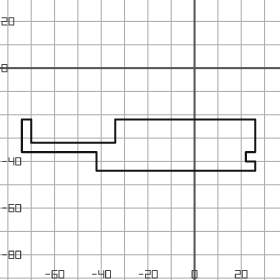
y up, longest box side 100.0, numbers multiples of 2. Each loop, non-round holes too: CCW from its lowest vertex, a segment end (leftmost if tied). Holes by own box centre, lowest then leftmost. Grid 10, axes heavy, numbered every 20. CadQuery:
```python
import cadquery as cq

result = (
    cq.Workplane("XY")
    .moveTo(-42.0, -44.0)
    .lineTo(26.0, -44.0)
    .lineTo(26.0, -40.0)
    .lineTo(22.0, -40.0)
    .lineTo(22.0, -36.0)
    .lineTo(26.0, -36.0)
    .lineTo(26.0, -22.0)
    .lineTo(-34.0, -22.0)
    .lineTo(-34.0, -32.0)
    .lineTo(-70.0, -32.0)
    .lineTo(-70.0, -22.0)
    .lineTo(-74.0, -22.0)
    .lineTo(-74.0, -36.0)
    .lineTo(-42.0, -36.0)
    .close()
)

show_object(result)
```